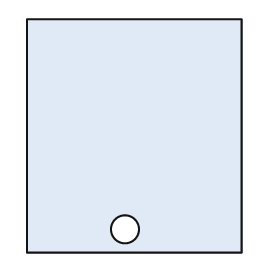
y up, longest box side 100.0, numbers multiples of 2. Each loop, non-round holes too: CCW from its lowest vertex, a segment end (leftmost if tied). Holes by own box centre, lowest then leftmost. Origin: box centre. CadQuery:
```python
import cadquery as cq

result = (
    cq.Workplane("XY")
    .moveTo(-46.0, -50.0)
    .lineTo(46.0, -50.0)
    .lineTo(46.0, 50.0)
    .lineTo(-46.0, 50.0)
    .close()
    .moveTo(-4.0, -40.0)
    .circle(6.0)
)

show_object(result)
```